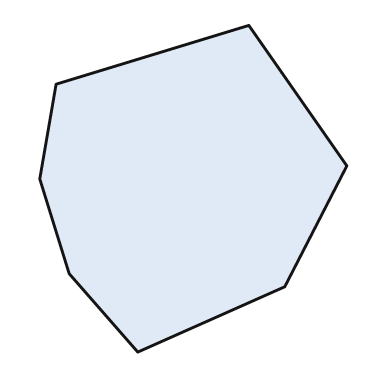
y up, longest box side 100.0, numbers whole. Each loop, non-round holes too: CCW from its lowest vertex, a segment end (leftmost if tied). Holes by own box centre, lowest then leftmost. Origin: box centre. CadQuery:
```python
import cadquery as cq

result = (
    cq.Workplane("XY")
    .moveTo(-17.0, -50.0)
    .lineTo(28.0, -30.0)
    .lineTo(47.0, 7.0)
    .lineTo(17.0, 50.0)
    .lineTo(-42.0, 32.0)
    .lineTo(-47.0, 3.0)
    .lineTo(-38.0, -26.0)
    .close()
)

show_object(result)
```